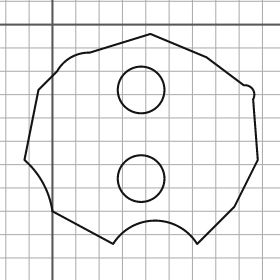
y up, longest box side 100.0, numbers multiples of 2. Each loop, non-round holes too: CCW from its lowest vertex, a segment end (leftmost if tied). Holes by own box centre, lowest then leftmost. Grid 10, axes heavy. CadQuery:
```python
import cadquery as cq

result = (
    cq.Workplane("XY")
    .moveTo(26.0, -94.0)
    .threePointArc((44.0, -84.0), (62.0, -94.0))
    .lineTo(78.0, -78.0)
    .lineTo(88.0, -58.0)
    .lineTo(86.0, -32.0)
    .threePointArc((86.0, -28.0), (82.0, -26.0))
    .lineTo(66.0, -14.0)
    .lineTo(42.0, -4.0)
    .lineTo(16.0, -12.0)
    .threePointArc((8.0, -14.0), (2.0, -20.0))
    .lineTo(-6.0, -28.0)
    .lineTo(-12.0, -58.0)
    .threePointArc((-4.0, -68.0), (0.0, -80.0))
    .close()
    .moveTo(38.0, -66.0)
    .circle(10.0)
    .moveTo(38.0, -28.0)
    .circle(10.0)
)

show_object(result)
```